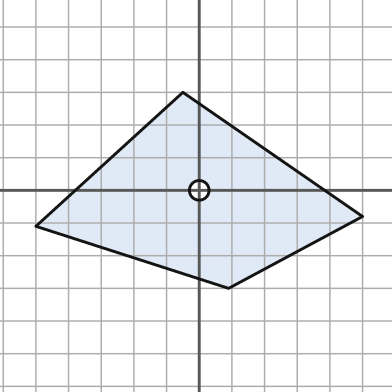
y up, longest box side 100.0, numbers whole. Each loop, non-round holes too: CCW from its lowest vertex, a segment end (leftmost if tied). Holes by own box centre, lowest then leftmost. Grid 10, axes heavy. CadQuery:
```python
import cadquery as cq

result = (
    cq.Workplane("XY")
    .moveTo(9.0, -30.0)
    .lineTo(50.0, -8.0)
    .lineTo(-5.0, 30.0)
    .lineTo(-50.0, -11.0)
    .close()
    .moveTo(0.0, 0.0)
    .circle(3.0)
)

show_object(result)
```